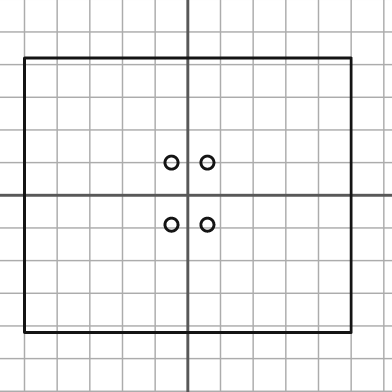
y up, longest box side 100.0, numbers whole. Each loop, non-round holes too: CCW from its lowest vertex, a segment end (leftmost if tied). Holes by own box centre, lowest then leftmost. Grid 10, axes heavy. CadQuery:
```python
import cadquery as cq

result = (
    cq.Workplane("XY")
    .moveTo(-50.0, -42.0)
    .lineTo(50.0, -42.0)
    .lineTo(50.0, 42.0)
    .lineTo(-50.0, 42.0)
    .close()
    .moveTo(-5.0, -9.0)
    .circle(2.0)
    .moveTo(6.0, -9.0)
    .circle(2.0)
    .moveTo(-5.0, 10.0)
    .circle(2.0)
    .moveTo(6.0, 10.0)
    .circle(2.0)
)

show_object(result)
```